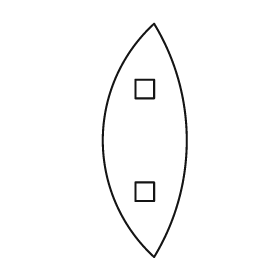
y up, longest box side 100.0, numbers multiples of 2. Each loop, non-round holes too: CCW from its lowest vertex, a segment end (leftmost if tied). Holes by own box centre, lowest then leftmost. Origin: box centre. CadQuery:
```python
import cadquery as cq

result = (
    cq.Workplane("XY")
    .moveTo(4.0, -50.0)
    .threePointArc((18.0, 0.0), (4.0, 50.0))
    .threePointArc((-18.0, 0.0), (4.0, -50.0))
    .close()
    .moveTo(-4.0, -26.0)
    .lineTo(4.0, -26.0)
    .lineTo(4.0, -18.0)
    .lineTo(-4.0, -18.0)
    .close()
    .moveTo(-4.0, 18.0)
    .lineTo(4.0, 18.0)
    .lineTo(4.0, 26.0)
    .lineTo(-4.0, 26.0)
    .close()
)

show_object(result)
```